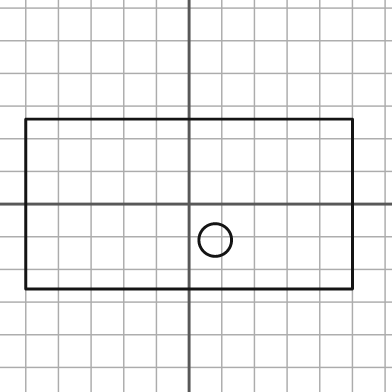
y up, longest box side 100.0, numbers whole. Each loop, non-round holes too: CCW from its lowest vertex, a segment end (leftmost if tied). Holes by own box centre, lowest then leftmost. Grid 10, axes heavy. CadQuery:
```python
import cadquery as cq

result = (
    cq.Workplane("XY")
    .moveTo(-50.0, -26.0)
    .lineTo(50.0, -26.0)
    .lineTo(50.0, 26.0)
    .lineTo(-50.0, 26.0)
    .close()
    .moveTo(8.0, -11.0)
    .circle(5.0)
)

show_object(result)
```